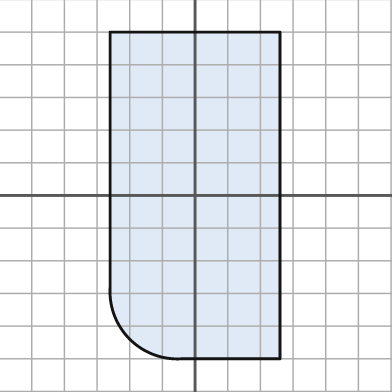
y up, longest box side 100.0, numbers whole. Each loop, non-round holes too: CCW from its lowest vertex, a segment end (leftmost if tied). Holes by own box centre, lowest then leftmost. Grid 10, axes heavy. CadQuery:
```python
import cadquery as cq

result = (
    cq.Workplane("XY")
    .moveTo(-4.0, -50.0)
    .lineTo(26.0, -50.0)
    .lineTo(26.0, 50.0)
    .lineTo(-26.0, 50.0)
    .lineTo(-26.0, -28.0)
    .threePointArc((-20.0, -44.0), (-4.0, -50.0))
    .close()
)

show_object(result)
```